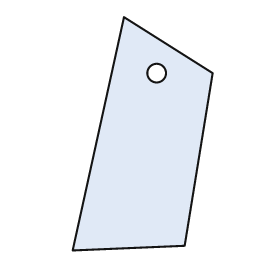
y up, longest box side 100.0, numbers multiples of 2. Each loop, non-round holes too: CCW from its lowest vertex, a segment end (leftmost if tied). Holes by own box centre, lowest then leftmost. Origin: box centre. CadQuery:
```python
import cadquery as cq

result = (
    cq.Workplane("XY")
    .moveTo(-30.0, -50.0)
    .lineTo(18.0, -48.0)
    .lineTo(30.0, 26.0)
    .lineTo(-8.0, 50.0)
    .close()
    .moveTo(6.0, 26.0)
    .circle(4.0)
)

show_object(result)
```